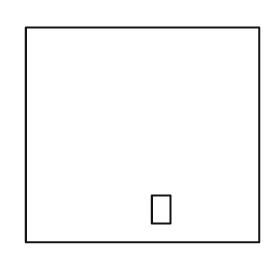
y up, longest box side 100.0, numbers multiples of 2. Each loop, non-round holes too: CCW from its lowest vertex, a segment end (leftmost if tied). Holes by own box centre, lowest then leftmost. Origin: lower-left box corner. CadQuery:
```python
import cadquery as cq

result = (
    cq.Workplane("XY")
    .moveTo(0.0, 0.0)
    .lineTo(100.0, 0.0)
    .lineTo(100.0, 92.0)
    .lineTo(0.0, 92.0)
    .close()
    .moveTo(54.0, 8.0)
    .lineTo(62.0, 8.0)
    .lineTo(62.0, 20.0)
    .lineTo(54.0, 20.0)
    .close()
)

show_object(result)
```